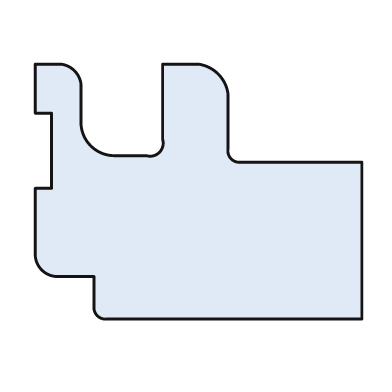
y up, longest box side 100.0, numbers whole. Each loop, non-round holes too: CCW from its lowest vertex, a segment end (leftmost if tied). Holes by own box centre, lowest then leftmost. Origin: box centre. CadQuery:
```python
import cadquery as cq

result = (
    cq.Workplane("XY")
    .moveTo(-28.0, -39.0)
    .lineTo(50.0, -39.0)
    .lineTo(50.0, 9.0)
    .lineTo(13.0, 9.0)
    .threePointArc((10.0, 10.0), (9.0, 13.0))
    .lineTo(9.0, 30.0)
    .threePointArc((6.0, 36.0), (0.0, 39.0))
    .lineTo(-11.0, 39.0)
    .lineTo(-11.0, 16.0)
    .threePointArc((-12.0, 12.0), (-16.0, 11.0))
    .lineTo(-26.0, 11.0)
    .threePointArc((-33.0, 14.0), (-36.0, 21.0))
    .lineTo(-36.0, 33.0)
    .threePointArc((-38.0, 37.0), (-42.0, 39.0))
    .lineTo(-50.0, 39.0)
    .lineTo(-50.0, 24.0)
    .lineTo(-45.0, 24.0)
    .lineTo(-45.0, 1.0)
    .lineTo(-50.0, 1.0)
    .lineTo(-50.0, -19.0)
    .threePointArc((-48.0, -24.0), (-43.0, -26.0))
    .lineTo(-32.0, -26.0)
    .lineTo(-32.0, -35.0)
    .threePointArc((-31.0, -38.0), (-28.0, -39.0))
    .close()
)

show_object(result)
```